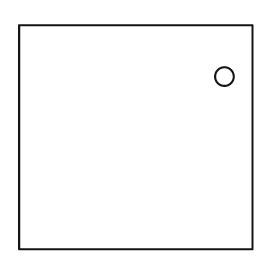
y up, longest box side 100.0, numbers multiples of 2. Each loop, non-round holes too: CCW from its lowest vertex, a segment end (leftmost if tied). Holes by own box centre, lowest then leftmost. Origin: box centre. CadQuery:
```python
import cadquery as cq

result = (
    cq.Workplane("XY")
    .moveTo(-50.0, -48.0)
    .lineTo(50.0, -48.0)
    .lineTo(50.0, 48.0)
    .lineTo(-50.0, 48.0)
    .close()
    .moveTo(38.0, 26.0)
    .circle(4.0)
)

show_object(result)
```